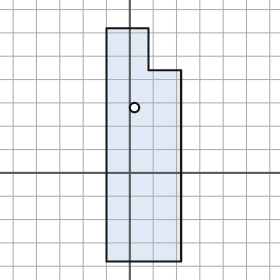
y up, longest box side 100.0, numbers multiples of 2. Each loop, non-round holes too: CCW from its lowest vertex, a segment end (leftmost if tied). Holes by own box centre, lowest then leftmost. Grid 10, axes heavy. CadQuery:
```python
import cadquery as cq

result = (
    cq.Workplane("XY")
    .moveTo(-10.0, -38.0)
    .lineTo(22.0, -38.0)
    .lineTo(22.0, 44.0)
    .lineTo(8.0, 44.0)
    .lineTo(8.0, 62.0)
    .lineTo(-10.0, 62.0)
    .close()
    .moveTo(2.0, 28.0)
    .circle(2.0)
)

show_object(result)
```